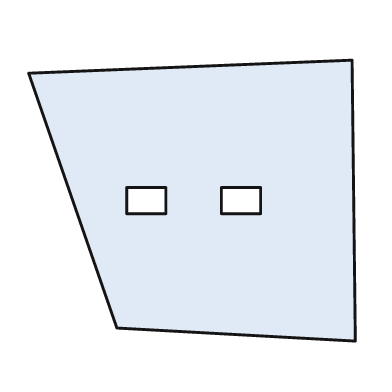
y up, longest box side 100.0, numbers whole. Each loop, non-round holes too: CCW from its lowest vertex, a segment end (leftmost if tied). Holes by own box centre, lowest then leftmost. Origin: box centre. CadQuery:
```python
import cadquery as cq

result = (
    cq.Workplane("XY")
    .moveTo(50.0, -43.0)
    .lineTo(49.0, 43.0)
    .lineTo(-50.0, 39.0)
    .lineTo(-23.0, -39.0)
    .close()
    .moveTo(-20.0, -4.0)
    .lineTo(-8.0, -4.0)
    .lineTo(-8.0, 4.0)
    .lineTo(-20.0, 4.0)
    .close()
    .moveTo(9.0, -4.0)
    .lineTo(21.0, -4.0)
    .lineTo(21.0, 4.0)
    .lineTo(9.0, 4.0)
    .close()
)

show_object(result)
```